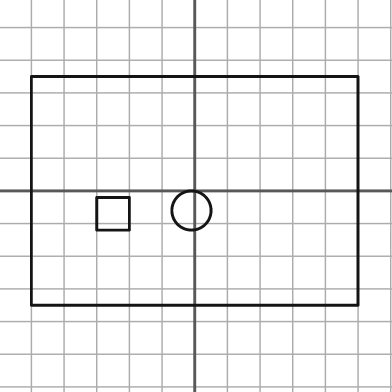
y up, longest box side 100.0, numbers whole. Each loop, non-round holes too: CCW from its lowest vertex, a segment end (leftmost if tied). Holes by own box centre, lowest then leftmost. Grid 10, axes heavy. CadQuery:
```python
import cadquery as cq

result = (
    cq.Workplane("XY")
    .moveTo(-50.0, -35.0)
    .lineTo(50.0, -35.0)
    .lineTo(50.0, 35.0)
    .lineTo(-50.0, 35.0)
    .close()
    .moveTo(-30.0, -12.0)
    .lineTo(-20.0, -12.0)
    .lineTo(-20.0, -2.0)
    .lineTo(-30.0, -2.0)
    .close()
    .moveTo(-1.0, -6.0)
    .circle(6.0)
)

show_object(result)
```